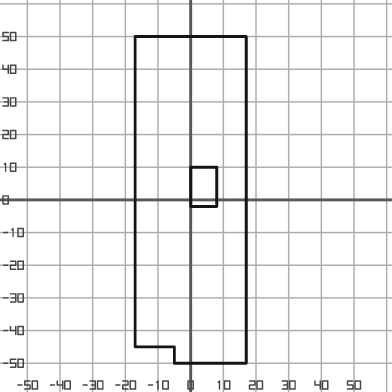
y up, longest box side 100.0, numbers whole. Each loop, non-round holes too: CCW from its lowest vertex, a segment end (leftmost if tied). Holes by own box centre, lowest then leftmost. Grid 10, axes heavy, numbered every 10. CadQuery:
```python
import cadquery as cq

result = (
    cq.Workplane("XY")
    .moveTo(-5.0, -50.0)
    .lineTo(17.0, -50.0)
    .lineTo(17.0, 50.0)
    .lineTo(-17.0, 50.0)
    .lineTo(-17.0, -45.0)
    .lineTo(-5.0, -45.0)
    .close()
    .moveTo(0.0, -2.0)
    .lineTo(8.0, -2.0)
    .lineTo(8.0, 10.0)
    .lineTo(0.0, 10.0)
    .close()
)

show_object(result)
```